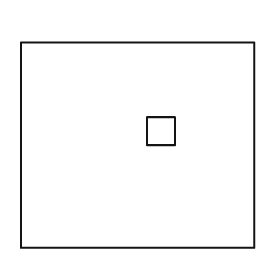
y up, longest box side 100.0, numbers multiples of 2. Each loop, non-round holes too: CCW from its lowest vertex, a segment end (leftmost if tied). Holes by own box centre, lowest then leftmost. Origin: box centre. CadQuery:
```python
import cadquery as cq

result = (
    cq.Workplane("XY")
    .moveTo(-50.0, -44.0)
    .lineTo(50.0, -44.0)
    .lineTo(50.0, 44.0)
    .lineTo(-50.0, 44.0)
    .close()
    .moveTo(4.0, 0.0)
    .lineTo(16.0, 0.0)
    .lineTo(16.0, 12.0)
    .lineTo(4.0, 12.0)
    .close()
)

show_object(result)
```